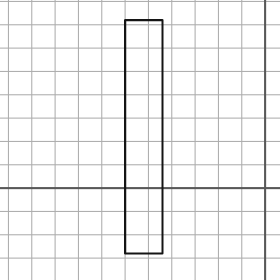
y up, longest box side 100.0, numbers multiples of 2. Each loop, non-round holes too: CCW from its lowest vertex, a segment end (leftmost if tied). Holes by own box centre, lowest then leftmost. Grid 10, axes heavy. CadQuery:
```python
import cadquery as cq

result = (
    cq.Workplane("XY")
    .moveTo(-60.0, -28.0)
    .lineTo(-44.0, -28.0)
    .lineTo(-44.0, 72.0)
    .lineTo(-60.0, 72.0)
    .close()
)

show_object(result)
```